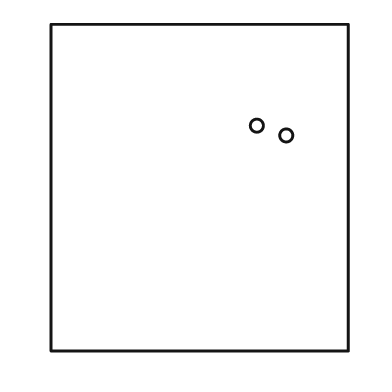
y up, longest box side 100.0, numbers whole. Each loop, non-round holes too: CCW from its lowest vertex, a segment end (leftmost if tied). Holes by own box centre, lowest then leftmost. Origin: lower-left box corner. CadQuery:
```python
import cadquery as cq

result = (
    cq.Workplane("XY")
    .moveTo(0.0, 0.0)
    .lineTo(91.0, 0.0)
    .lineTo(91.0, 100.0)
    .lineTo(0.0, 100.0)
    .close()
    .moveTo(72.0, 66.0)
    .circle(2.0)
    .moveTo(63.0, 69.0)
    .circle(2.0)
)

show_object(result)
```